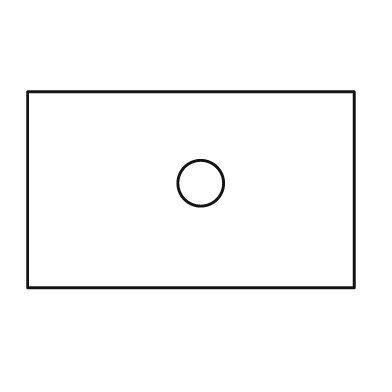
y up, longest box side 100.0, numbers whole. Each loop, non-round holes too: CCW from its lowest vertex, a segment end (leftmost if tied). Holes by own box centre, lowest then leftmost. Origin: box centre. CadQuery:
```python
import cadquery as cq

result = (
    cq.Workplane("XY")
    .moveTo(-50.0, -30.0)
    .lineTo(50.0, -30.0)
    .lineTo(50.0, 30.0)
    .lineTo(-50.0, 30.0)
    .close()
    .moveTo(3.0, 2.0)
    .circle(7.0)
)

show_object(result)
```